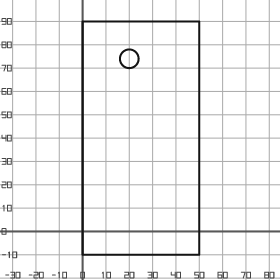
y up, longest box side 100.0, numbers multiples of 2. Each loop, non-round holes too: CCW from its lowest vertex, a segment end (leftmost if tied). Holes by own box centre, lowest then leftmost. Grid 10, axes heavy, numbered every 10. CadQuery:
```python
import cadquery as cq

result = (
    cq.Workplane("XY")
    .moveTo(0.0, -10.0)
    .lineTo(50.0, -10.0)
    .lineTo(50.0, 90.0)
    .lineTo(0.0, 90.0)
    .close()
    .moveTo(20.0, 74.0)
    .circle(4.0)
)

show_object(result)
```